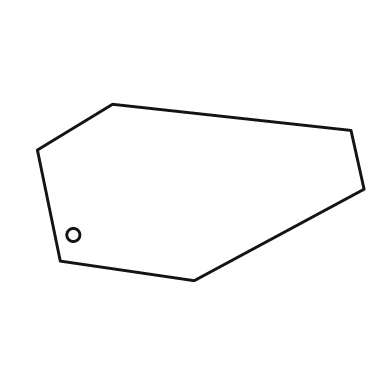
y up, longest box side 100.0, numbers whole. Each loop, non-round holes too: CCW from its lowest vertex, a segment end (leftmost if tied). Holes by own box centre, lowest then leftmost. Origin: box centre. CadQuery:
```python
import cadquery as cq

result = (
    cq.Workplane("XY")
    .moveTo(-2.0, -27.0)
    .lineTo(50.0, 1.0)
    .lineTo(46.0, 19.0)
    .lineTo(-27.0, 27.0)
    .lineTo(-50.0, 13.0)
    .lineTo(-43.0, -21.0)
    .close()
    .moveTo(-39.0, -13.0)
    .circle(2.0)
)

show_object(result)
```